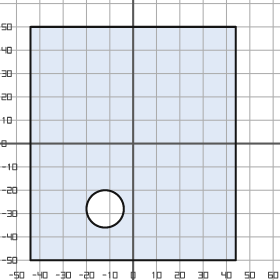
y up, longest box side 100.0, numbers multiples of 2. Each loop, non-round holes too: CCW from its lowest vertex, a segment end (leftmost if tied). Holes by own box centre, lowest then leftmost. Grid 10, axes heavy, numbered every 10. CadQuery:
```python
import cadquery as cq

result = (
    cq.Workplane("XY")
    .moveTo(-44.0, -50.0)
    .lineTo(44.0, -50.0)
    .lineTo(44.0, 50.0)
    .lineTo(-44.0, 50.0)
    .close()
    .moveTo(-12.0, -28.0)
    .circle(8.0)
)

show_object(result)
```